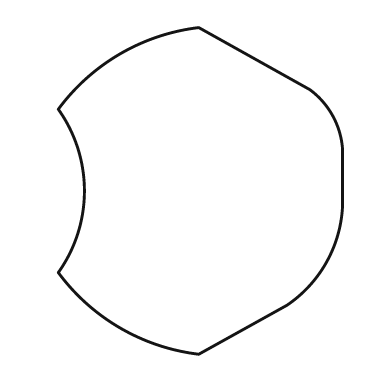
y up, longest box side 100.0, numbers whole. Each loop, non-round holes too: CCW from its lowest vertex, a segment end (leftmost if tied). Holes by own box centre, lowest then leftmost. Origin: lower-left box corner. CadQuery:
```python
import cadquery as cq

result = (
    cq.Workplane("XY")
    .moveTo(43.0, 0.0)
    .lineTo(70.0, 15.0)
    .threePointArc((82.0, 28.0), (87.0, 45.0))
    .lineTo(87.0, 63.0)
    .threePointArc((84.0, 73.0), (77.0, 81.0))
    .lineTo(43.0, 100.0)
    .threePointArc((19.0, 92.0), (0.0, 75.0))
    .threePointArc((8.0, 50.0), (0.0, 25.0))
    .threePointArc((19.0, 8.0), (43.0, 0.0))
    .close()
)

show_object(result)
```